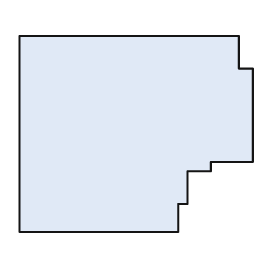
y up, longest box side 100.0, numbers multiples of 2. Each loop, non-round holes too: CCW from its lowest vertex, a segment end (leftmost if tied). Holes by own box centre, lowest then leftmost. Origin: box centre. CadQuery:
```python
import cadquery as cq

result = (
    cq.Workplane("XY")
    .moveTo(-50.0, -42.0)
    .lineTo(18.0, -42.0)
    .lineTo(18.0, -30.0)
    .lineTo(22.0, -30.0)
    .lineTo(22.0, -16.0)
    .lineTo(32.0, -16.0)
    .lineTo(32.0, -12.0)
    .lineTo(50.0, -12.0)
    .lineTo(50.0, 28.0)
    .lineTo(44.0, 28.0)
    .lineTo(44.0, 42.0)
    .lineTo(-50.0, 42.0)
    .close()
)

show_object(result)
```